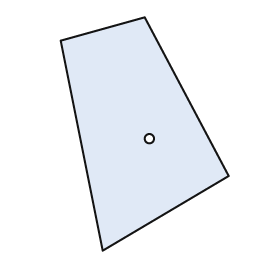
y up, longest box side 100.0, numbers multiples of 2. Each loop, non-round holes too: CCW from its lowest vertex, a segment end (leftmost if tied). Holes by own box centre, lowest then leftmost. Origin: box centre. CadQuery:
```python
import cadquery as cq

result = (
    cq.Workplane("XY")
    .moveTo(-18.0, -50.0)
    .lineTo(36.0, -18.0)
    .lineTo(0.0, 50.0)
    .lineTo(-36.0, 40.0)
    .close()
    .moveTo(2.0, -2.0)
    .circle(2.0)
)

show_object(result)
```